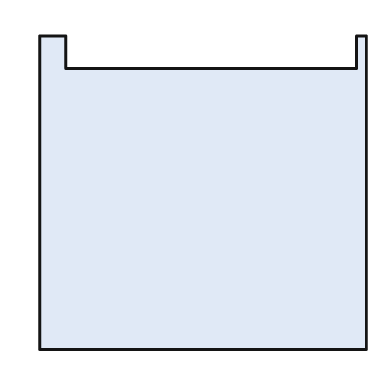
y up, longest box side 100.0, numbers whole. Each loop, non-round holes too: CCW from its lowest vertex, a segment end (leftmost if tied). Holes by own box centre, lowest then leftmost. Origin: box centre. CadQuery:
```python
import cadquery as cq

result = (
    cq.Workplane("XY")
    .moveTo(-50.0, -48.0)
    .lineTo(50.0, -48.0)
    .lineTo(50.0, 48.0)
    .lineTo(47.0, 48.0)
    .lineTo(47.0, 38.0)
    .lineTo(-42.0, 38.0)
    .lineTo(-42.0, 48.0)
    .lineTo(-50.0, 48.0)
    .close()
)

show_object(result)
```